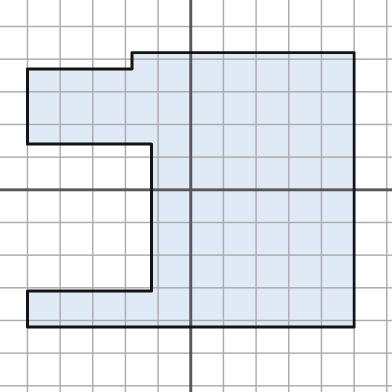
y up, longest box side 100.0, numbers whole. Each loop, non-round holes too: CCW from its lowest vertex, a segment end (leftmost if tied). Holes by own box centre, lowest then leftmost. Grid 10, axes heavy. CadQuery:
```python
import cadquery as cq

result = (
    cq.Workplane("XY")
    .moveTo(-50.0, -42.0)
    .lineTo(50.0, -42.0)
    .lineTo(50.0, 42.0)
    .lineTo(-18.0, 42.0)
    .lineTo(-18.0, 37.0)
    .lineTo(-50.0, 37.0)
    .lineTo(-50.0, 14.0)
    .lineTo(-12.0, 14.0)
    .lineTo(-12.0, -31.0)
    .lineTo(-50.0, -31.0)
    .close()
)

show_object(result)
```